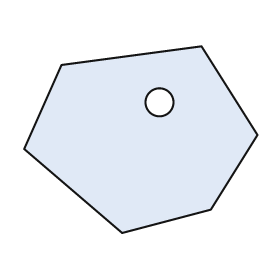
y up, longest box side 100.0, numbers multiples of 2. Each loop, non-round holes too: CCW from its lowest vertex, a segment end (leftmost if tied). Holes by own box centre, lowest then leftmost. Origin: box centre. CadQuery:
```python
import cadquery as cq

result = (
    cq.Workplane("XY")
    .moveTo(-8.0, -40.0)
    .lineTo(30.0, -30.0)
    .lineTo(50.0, 2.0)
    .lineTo(26.0, 40.0)
    .lineTo(-34.0, 32.0)
    .lineTo(-50.0, -4.0)
    .close()
    .moveTo(8.0, 16.0)
    .circle(6.0)
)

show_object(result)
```